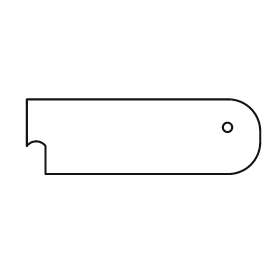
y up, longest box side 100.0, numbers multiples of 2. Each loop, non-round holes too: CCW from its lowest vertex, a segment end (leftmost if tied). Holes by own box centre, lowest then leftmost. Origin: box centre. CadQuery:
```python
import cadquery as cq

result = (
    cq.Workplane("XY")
    .moveTo(-42.0, -16.0)
    .lineTo(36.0, -16.0)
    .threePointArc((46.0, -12.0), (50.0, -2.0))
    .lineTo(50.0, 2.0)
    .threePointArc((46.0, 12.0), (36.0, 16.0))
    .lineTo(-50.0, 16.0)
    .lineTo(-50.0, -4.0)
    .threePointArc((-46.0, -2.0), (-42.0, -4.0))
    .close()
    .moveTo(36.0, 4.0)
    .circle(2.0)
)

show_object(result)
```